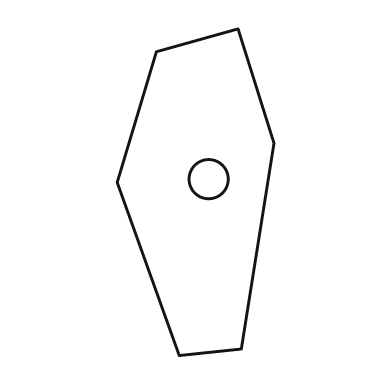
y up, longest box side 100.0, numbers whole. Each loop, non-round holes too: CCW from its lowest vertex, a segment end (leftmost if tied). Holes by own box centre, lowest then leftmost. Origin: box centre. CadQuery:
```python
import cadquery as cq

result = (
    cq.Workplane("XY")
    .moveTo(-5.0, -50.0)
    .lineTo(14.0, -48.0)
    .lineTo(24.0, 15.0)
    .lineTo(13.0, 50.0)
    .lineTo(-12.0, 43.0)
    .lineTo(-24.0, 3.0)
    .close()
    .moveTo(4.0, 4.0)
    .circle(6.0)
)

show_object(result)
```